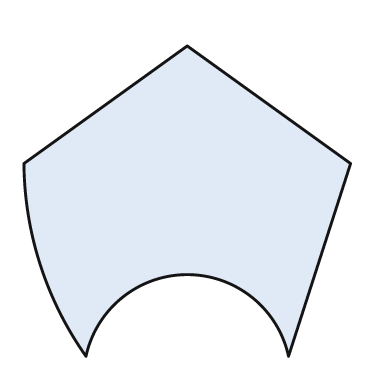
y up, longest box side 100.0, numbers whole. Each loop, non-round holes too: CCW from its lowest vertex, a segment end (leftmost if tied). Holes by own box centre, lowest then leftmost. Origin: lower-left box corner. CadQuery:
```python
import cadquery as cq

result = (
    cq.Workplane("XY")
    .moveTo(19.0, 0.0)
    .threePointArc((50.0, 25.0), (81.0, 0.0))
    .lineTo(100.0, 59.0)
    .lineTo(50.0, 95.0)
    .lineTo(0.0, 59.0)
    .threePointArc((5.0, 28.0), (19.0, 0.0))
    .close()
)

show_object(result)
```